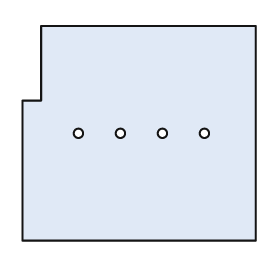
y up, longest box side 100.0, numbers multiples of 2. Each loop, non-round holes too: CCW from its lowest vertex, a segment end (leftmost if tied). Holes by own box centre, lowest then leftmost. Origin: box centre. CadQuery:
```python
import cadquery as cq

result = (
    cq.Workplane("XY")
    .moveTo(-50.0, -46.0)
    .lineTo(50.0, -46.0)
    .lineTo(50.0, 46.0)
    .lineTo(-42.0, 46.0)
    .lineTo(-42.0, 14.0)
    .lineTo(-50.0, 14.0)
    .close()
    .moveTo(-26.0, 0.0)
    .circle(2.0)
    .moveTo(-8.0, 0.0)
    .circle(2.0)
    .moveTo(10.0, 0.0)
    .circle(2.0)
    .moveTo(28.0, 0.0)
    .circle(2.0)
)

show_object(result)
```